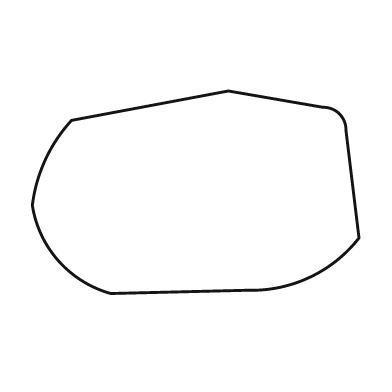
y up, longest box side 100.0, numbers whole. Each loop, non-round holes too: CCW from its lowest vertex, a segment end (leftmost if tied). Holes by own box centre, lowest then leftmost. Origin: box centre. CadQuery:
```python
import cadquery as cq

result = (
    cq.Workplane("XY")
    .moveTo(-26.0, -31.0)
    .lineTo(16.0, -30.0)
    .threePointArc((35.0, -26.0), (50.0, -14.0))
    .lineTo(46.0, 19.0)
    .threePointArc((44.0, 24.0), (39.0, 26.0))
    .lineTo(10.0, 31.0)
    .lineTo(-38.0, 22.0)
    .threePointArc((-46.0, 10.0), (-50.0, -4.0))
    .threePointArc((-42.0, -21.0), (-26.0, -31.0))
    .close()
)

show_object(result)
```